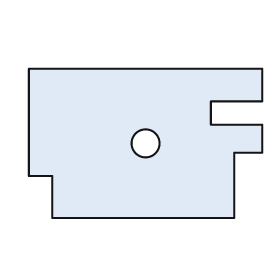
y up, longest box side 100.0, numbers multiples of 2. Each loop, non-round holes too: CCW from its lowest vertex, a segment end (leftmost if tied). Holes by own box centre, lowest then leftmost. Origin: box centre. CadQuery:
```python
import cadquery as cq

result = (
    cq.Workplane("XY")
    .moveTo(-40.0, -32.0)
    .lineTo(38.0, -32.0)
    .lineTo(38.0, -4.0)
    .lineTo(50.0, -4.0)
    .lineTo(50.0, 8.0)
    .lineTo(28.0, 8.0)
    .lineTo(28.0, 18.0)
    .lineTo(50.0, 18.0)
    .lineTo(50.0, 32.0)
    .lineTo(-50.0, 32.0)
    .lineTo(-50.0, -14.0)
    .lineTo(-40.0, -14.0)
    .close()
    .moveTo(0.0, 0.0)
    .circle(6.0)
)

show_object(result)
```